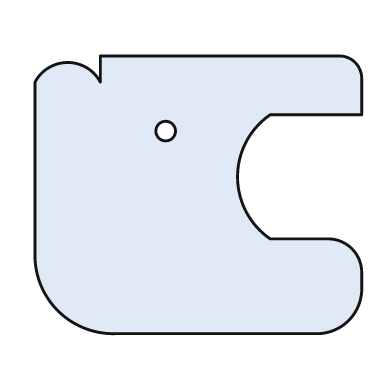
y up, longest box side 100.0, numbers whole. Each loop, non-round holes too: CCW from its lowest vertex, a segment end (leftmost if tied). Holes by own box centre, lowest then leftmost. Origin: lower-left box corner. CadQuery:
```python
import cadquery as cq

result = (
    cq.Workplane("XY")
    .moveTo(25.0, 0.0)
    .lineTo(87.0, 0.0)
    .threePointArc((96.0, 4.0), (100.0, 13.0))
    .lineTo(100.0, 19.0)
    .threePointArc((97.0, 26.0), (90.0, 29.0))
    .lineTo(72.0, 29.0)
    .threePointArc((62.0, 48.0), (72.0, 67.0))
    .lineTo(100.0, 67.0)
    .lineTo(100.0, 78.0)
    .threePointArc((98.0, 83.0), (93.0, 85.0))
    .lineTo(20.0, 85.0)
    .lineTo(20.0, 77.0)
    .threePointArc((10.0, 83.0), (0.0, 77.0))
    .lineTo(0.0, 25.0)
    .threePointArc((7.0, 7.0), (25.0, 0.0))
    .close()
    .moveTo(40.0, 62.0)
    .circle(3.0)
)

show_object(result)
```